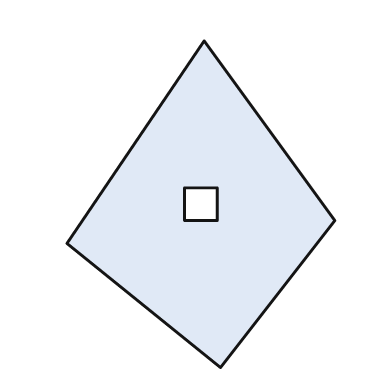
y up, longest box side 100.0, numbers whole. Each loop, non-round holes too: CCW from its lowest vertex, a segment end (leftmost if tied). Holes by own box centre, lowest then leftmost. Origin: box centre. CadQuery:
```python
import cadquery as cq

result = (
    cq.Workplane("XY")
    .moveTo(6.0, -50.0)
    .lineTo(41.0, -5.0)
    .lineTo(1.0, 50.0)
    .lineTo(-41.0, -12.0)
    .close()
    .moveTo(-5.0, -5.0)
    .lineTo(5.0, -5.0)
    .lineTo(5.0, 5.0)
    .lineTo(-5.0, 5.0)
    .close()
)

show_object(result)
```